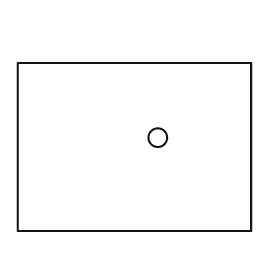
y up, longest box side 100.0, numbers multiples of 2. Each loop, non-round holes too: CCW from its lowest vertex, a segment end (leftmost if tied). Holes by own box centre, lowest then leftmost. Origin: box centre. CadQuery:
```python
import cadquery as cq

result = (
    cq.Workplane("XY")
    .moveTo(-50.0, -36.0)
    .lineTo(50.0, -36.0)
    .lineTo(50.0, 36.0)
    .lineTo(-50.0, 36.0)
    .close()
    .moveTo(10.0, 4.0)
    .circle(4.0)
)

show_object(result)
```